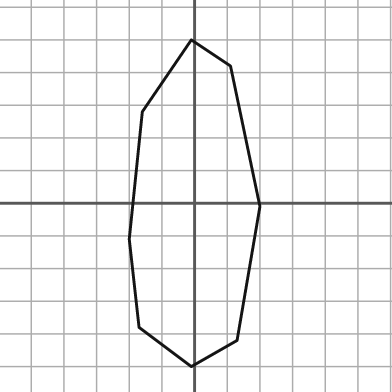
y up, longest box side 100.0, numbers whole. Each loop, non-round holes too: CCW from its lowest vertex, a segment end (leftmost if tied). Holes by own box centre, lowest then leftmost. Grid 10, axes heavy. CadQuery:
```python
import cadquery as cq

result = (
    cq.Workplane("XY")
    .moveTo(-1.0, -50.0)
    .lineTo(13.0, -42.0)
    .lineTo(20.0, -1.0)
    .lineTo(11.0, 42.0)
    .lineTo(-1.0, 50.0)
    .lineTo(-16.0, 28.0)
    .lineTo(-20.0, -11.0)
    .lineTo(-17.0, -38.0)
    .close()
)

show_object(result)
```